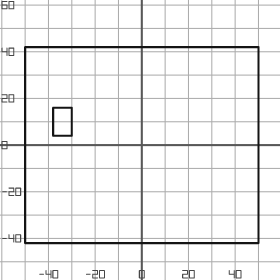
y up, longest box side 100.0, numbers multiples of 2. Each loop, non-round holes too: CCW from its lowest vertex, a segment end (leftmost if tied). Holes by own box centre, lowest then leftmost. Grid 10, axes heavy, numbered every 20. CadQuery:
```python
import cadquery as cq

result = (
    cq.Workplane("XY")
    .moveTo(-50.0, -42.0)
    .lineTo(50.0, -42.0)
    .lineTo(50.0, 42.0)
    .lineTo(-50.0, 42.0)
    .close()
    .moveTo(-38.0, 4.0)
    .lineTo(-30.0, 4.0)
    .lineTo(-30.0, 16.0)
    .lineTo(-38.0, 16.0)
    .close()
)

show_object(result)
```